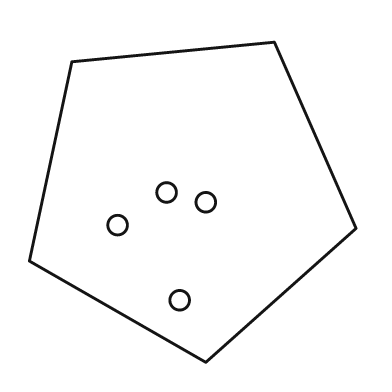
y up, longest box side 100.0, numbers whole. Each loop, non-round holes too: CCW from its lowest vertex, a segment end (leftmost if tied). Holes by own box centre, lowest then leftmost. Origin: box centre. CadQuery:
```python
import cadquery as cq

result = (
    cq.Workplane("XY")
    .moveTo(4.0, -49.0)
    .lineTo(50.0, -8.0)
    .lineTo(25.0, 49.0)
    .lineTo(-37.0, 43.0)
    .lineTo(-50.0, -18.0)
    .close()
    .moveTo(-4.0, -30.0)
    .circle(3.0)
    .moveTo(-23.0, -7.0)
    .circle(3.0)
    .moveTo(4.0, 0.0)
    .circle(3.0)
    .moveTo(-8.0, 3.0)
    .circle(3.0)
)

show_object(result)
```